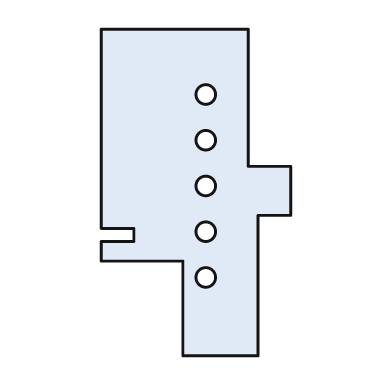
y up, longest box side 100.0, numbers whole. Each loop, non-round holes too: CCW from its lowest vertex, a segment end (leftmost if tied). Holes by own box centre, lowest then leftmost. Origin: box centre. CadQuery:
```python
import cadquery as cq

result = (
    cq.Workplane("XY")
    .moveTo(-4.0, -50.0)
    .lineTo(19.0, -50.0)
    .lineTo(19.0, -7.0)
    .lineTo(29.0, -7.0)
    .lineTo(29.0, 8.0)
    .lineTo(16.0, 8.0)
    .lineTo(16.0, 50.0)
    .lineTo(-29.0, 50.0)
    .lineTo(-29.0, -11.0)
    .lineTo(-19.0, -11.0)
    .lineTo(-19.0, -15.0)
    .lineTo(-29.0, -15.0)
    .lineTo(-29.0, -21.0)
    .lineTo(-4.0, -21.0)
    .close()
    .moveTo(3.0, -26.0)
    .circle(3.0)
    .moveTo(3.0, -12.0)
    .circle(3.0)
    .moveTo(3.0, 2.0)
    .circle(3.0)
    .moveTo(3.0, 16.0)
    .circle(3.0)
    .moveTo(3.0, 30.0)
    .circle(3.0)
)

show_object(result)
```